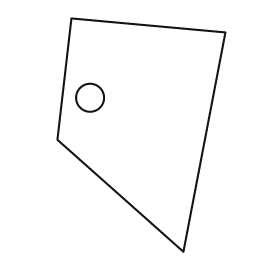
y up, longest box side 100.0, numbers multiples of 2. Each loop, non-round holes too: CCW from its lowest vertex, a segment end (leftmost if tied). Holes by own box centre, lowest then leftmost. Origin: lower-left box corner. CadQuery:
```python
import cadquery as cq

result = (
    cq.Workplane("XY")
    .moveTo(54.0, 0.0)
    .lineTo(72.0, 94.0)
    .lineTo(6.0, 100.0)
    .lineTo(0.0, 48.0)
    .close()
    .moveTo(14.0, 66.0)
    .circle(6.0)
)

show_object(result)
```